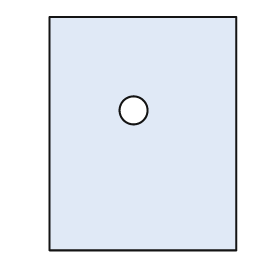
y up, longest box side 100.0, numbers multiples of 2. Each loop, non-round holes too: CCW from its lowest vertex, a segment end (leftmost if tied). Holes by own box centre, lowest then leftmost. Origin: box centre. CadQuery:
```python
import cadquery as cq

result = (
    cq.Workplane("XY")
    .moveTo(-40.0, -50.0)
    .lineTo(40.0, -50.0)
    .lineTo(40.0, 50.0)
    .lineTo(-40.0, 50.0)
    .close()
    .moveTo(-4.0, 10.0)
    .circle(6.0)
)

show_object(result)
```